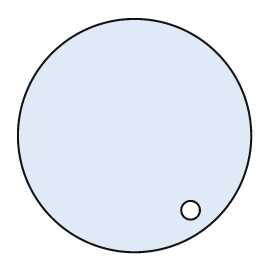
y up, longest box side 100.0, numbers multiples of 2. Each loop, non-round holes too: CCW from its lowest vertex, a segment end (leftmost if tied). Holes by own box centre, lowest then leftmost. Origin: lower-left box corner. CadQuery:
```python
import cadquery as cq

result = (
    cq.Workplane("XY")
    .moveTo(50.0, 50.0)
    .circle(50.0)
    .moveTo(74.0, 18.0)
    .circle(4.0)
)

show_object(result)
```